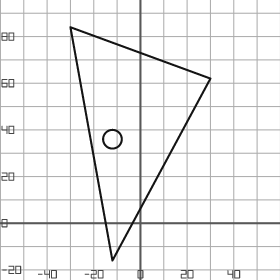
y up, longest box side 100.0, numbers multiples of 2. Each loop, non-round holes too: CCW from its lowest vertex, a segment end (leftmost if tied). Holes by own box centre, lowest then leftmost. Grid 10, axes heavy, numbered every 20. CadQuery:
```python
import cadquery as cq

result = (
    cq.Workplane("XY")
    .moveTo(-12.0, -16.0)
    .lineTo(30.0, 62.0)
    .lineTo(-30.0, 84.0)
    .close()
    .moveTo(-12.0, 36.0)
    .circle(4.0)
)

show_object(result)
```